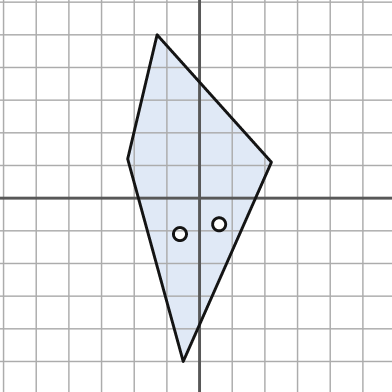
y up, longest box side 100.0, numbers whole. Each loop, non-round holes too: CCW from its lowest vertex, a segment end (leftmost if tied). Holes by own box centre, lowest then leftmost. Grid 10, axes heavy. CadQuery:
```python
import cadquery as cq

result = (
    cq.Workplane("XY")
    .moveTo(-5.0, -50.0)
    .lineTo(22.0, 11.0)
    .lineTo(-13.0, 50.0)
    .lineTo(-22.0, 12.0)
    .close()
    .moveTo(-6.0, -11.0)
    .circle(2.0)
    .moveTo(6.0, -8.0)
    .circle(2.0)
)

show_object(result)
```